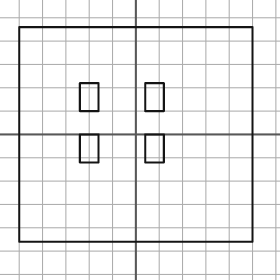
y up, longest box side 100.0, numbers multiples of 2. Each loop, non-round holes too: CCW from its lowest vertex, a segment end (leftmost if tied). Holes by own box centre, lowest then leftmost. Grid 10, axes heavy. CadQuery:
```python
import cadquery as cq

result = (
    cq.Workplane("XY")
    .moveTo(-50.0, -46.0)
    .lineTo(50.0, -46.0)
    .lineTo(50.0, 46.0)
    .lineTo(-50.0, 46.0)
    .close()
    .moveTo(-24.0, -12.0)
    .lineTo(-16.0, -12.0)
    .lineTo(-16.0, 0.0)
    .lineTo(-24.0, 0.0)
    .close()
    .moveTo(4.0, -12.0)
    .lineTo(12.0, -12.0)
    .lineTo(12.0, 0.0)
    .lineTo(4.0, 0.0)
    .close()
    .moveTo(-24.0, 10.0)
    .lineTo(-16.0, 10.0)
    .lineTo(-16.0, 22.0)
    .lineTo(-24.0, 22.0)
    .close()
    .moveTo(4.0, 10.0)
    .lineTo(12.0, 10.0)
    .lineTo(12.0, 22.0)
    .lineTo(4.0, 22.0)
    .close()
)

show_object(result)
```